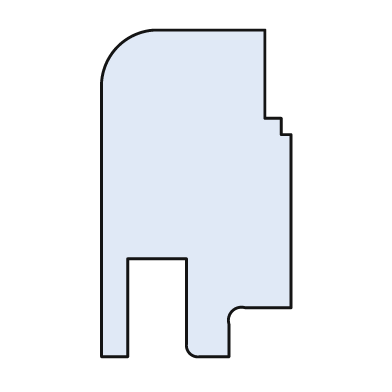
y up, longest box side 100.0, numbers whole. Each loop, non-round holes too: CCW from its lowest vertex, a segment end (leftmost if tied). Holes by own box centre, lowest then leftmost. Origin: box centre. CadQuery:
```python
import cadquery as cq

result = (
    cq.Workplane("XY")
    .moveTo(-29.0, -50.0)
    .lineTo(-21.0, -50.0)
    .lineTo(-21.0, -20.0)
    .lineTo(-3.0, -20.0)
    .lineTo(-3.0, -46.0)
    .threePointArc((-2.0, -49.0), (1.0, -50.0))
    .lineTo(10.0, -50.0)
    .lineTo(10.0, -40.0)
    .threePointArc((11.0, -36.0), (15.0, -35.0))
    .lineTo(29.0, -35.0)
    .lineTo(29.0, 18.0)
    .lineTo(26.0, 18.0)
    .lineTo(26.0, 23.0)
    .lineTo(21.0, 23.0)
    .lineTo(21.0, 50.0)
    .lineTo(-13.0, 50.0)
    .threePointArc((-24.0, 45.0), (-29.0, 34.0))
    .close()
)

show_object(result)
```